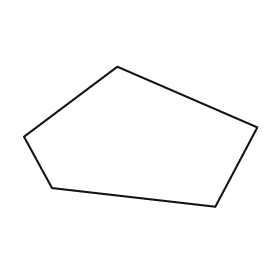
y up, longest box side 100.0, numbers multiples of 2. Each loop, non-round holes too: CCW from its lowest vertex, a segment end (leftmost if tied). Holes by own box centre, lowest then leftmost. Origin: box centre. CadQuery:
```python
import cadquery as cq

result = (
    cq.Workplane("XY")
    .moveTo(32.0, -30.0)
    .lineTo(50.0, 4.0)
    .lineTo(-10.0, 30.0)
    .lineTo(-50.0, 0.0)
    .lineTo(-38.0, -22.0)
    .close()
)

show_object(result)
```